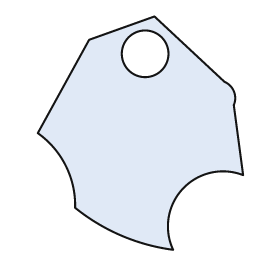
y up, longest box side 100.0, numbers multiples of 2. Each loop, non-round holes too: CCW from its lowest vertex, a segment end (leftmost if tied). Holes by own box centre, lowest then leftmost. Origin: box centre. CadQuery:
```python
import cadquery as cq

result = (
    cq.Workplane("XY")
    .moveTo(14.0, -50.0)
    .threePointArc((18.0, -24.0), (44.0, -18.0))
    .lineTo(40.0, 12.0)
    .threePointArc((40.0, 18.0), (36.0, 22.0))
    .lineTo(6.0, 50.0)
    .lineTo(-22.0, 40.0)
    .lineTo(-44.0, 0.0)
    .threePointArc((-32.0, -14.0), (-28.0, -32.0))
    .threePointArc((-8.0, -44.0), (14.0, -50.0))
    .close()
    .moveTo(2.0, 34.0)
    .circle(10.0)
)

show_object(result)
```